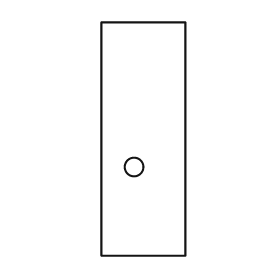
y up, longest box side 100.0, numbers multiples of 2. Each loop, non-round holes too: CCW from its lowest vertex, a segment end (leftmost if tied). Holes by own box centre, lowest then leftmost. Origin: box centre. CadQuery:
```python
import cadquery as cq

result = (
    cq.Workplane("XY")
    .moveTo(-18.0, -50.0)
    .lineTo(18.0, -50.0)
    .lineTo(18.0, 50.0)
    .lineTo(-18.0, 50.0)
    .close()
    .moveTo(-4.0, -12.0)
    .circle(4.0)
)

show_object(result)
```